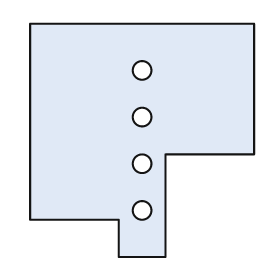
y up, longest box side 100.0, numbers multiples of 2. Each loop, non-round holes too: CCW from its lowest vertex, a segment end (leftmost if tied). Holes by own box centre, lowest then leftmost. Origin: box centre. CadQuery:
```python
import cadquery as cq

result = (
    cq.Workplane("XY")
    .moveTo(-10.0, -50.0)
    .lineTo(10.0, -50.0)
    .lineTo(10.0, -6.0)
    .lineTo(48.0, -6.0)
    .lineTo(48.0, 50.0)
    .lineTo(-48.0, 50.0)
    .lineTo(-48.0, -34.0)
    .lineTo(-10.0, -34.0)
    .close()
    .moveTo(0.0, -30.0)
    .circle(4.0)
    .moveTo(0.0, -10.0)
    .circle(4.0)
    .moveTo(0.0, 10.0)
    .circle(4.0)
    .moveTo(0.0, 30.0)
    .circle(4.0)
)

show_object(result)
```